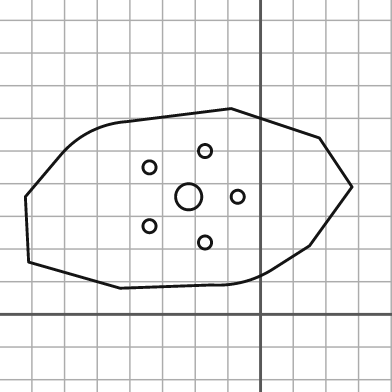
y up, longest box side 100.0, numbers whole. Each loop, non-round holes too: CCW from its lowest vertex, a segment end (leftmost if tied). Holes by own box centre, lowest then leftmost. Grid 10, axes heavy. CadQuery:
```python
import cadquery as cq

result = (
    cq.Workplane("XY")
    .moveTo(-43.0, 8.0)
    .lineTo(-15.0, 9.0)
    .threePointArc((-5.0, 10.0), (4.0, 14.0))
    .lineTo(15.0, 21.0)
    .lineTo(28.0, 39.0)
    .lineTo(18.0, 54.0)
    .lineTo(-9.0, 63.0)
    .lineTo(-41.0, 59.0)
    .threePointArc((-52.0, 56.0), (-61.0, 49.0))
    .lineTo(-72.0, 36.0)
    .lineTo(-71.0, 16.0)
    .close()
    .moveTo(-17.0, 22.0)
    .circle(2.0)
    .moveTo(-34.0, 27.0)
    .circle(2.0)
    .moveTo(-22.0, 36.0)
    .circle(4.0)
    .moveTo(-7.0, 36.0)
    .circle(2.0)
    .moveTo(-34.0, 45.0)
    .circle(2.0)
    .moveTo(-17.0, 50.0)
    .circle(2.0)
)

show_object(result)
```